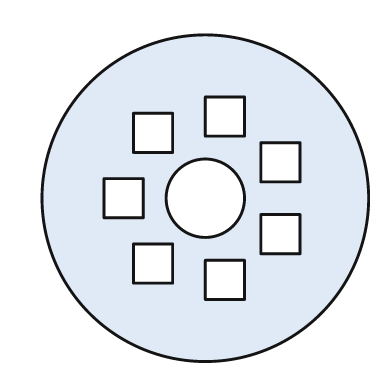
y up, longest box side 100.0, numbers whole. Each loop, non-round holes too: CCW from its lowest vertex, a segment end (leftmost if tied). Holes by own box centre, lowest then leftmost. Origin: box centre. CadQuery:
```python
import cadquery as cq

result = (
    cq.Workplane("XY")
    .moveTo(0.0, 0.0)
    .circle(50.0)
    .moveTo(0.0, -31.0)
    .lineTo(12.0, -31.0)
    .lineTo(12.0, -19.0)
    .lineTo(0.0, -19.0)
    .close()
    .moveTo(-22.0, -26.0)
    .lineTo(-10.0, -26.0)
    .lineTo(-10.0, -14.0)
    .lineTo(-22.0, -14.0)
    .close()
    .moveTo(17.0, -17.0)
    .lineTo(29.0, -17.0)
    .lineTo(29.0, -5.0)
    .lineTo(17.0, -5.0)
    .close()
    .moveTo(-31.0, -6.0)
    .lineTo(-19.0, -6.0)
    .lineTo(-19.0, 6.0)
    .lineTo(-31.0, 6.0)
    .close()
    .moveTo(0.0, 0.0)
    .circle(12.0)
    .moveTo(17.0, 5.0)
    .lineTo(29.0, 5.0)
    .lineTo(29.0, 17.0)
    .lineTo(17.0, 17.0)
    .close()
    .moveTo(-22.0, 14.0)
    .lineTo(-10.0, 14.0)
    .lineTo(-10.0, 26.0)
    .lineTo(-22.0, 26.0)
    .close()
    .moveTo(0.0, 19.0)
    .lineTo(12.0, 19.0)
    .lineTo(12.0, 31.0)
    .lineTo(0.0, 31.0)
    .close()
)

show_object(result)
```